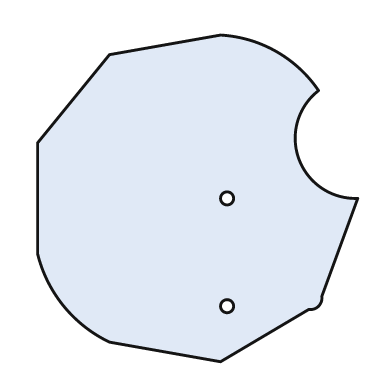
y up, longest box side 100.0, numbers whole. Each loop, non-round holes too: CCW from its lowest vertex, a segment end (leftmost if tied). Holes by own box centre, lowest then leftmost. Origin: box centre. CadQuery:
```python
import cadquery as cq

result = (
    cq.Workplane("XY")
    .moveTo(7.0, -50.0)
    .lineTo(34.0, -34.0)
    .threePointArc((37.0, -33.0), (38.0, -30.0))
    .lineTo(49.0, 0.0)
    .threePointArc((31.0, 12.0), (37.0, 33.0))
    .threePointArc((24.0, 45.0), (7.0, 50.0))
    .lineTo(-27.0, 44.0)
    .lineTo(-49.0, 17.0)
    .lineTo(-49.0, -17.0)
    .threePointArc((-41.0, -33.0), (-27.0, -44.0))
    .close()
    .moveTo(9.0, -33.0)
    .circle(2.0)
    .moveTo(9.0, 0.0)
    .circle(2.0)
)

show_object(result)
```